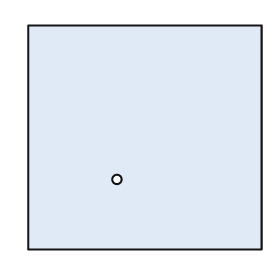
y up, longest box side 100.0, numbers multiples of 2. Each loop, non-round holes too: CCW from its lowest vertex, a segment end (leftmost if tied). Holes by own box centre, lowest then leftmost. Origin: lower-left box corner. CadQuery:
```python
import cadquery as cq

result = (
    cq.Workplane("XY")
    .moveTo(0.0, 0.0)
    .lineTo(100.0, 0.0)
    .lineTo(100.0, 96.0)
    .lineTo(0.0, 96.0)
    .close()
    .moveTo(38.0, 30.0)
    .circle(2.0)
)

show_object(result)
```